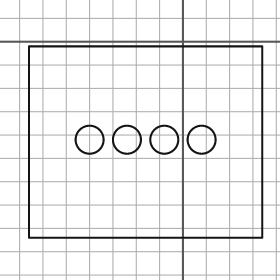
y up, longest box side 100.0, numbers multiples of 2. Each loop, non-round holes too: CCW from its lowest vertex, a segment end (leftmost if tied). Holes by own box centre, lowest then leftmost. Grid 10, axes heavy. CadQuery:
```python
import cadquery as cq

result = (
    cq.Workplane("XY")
    .moveTo(-66.0, -84.0)
    .lineTo(34.0, -84.0)
    .lineTo(34.0, -2.0)
    .lineTo(-66.0, -2.0)
    .close()
    .moveTo(-40.0, -42.0)
    .circle(6.0)
    .moveTo(-24.0, -42.0)
    .circle(6.0)
    .moveTo(-8.0, -42.0)
    .circle(6.0)
    .moveTo(8.0, -42.0)
    .circle(6.0)
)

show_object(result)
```